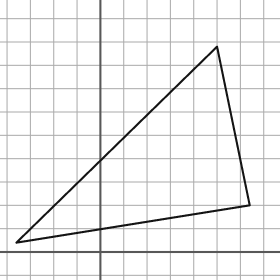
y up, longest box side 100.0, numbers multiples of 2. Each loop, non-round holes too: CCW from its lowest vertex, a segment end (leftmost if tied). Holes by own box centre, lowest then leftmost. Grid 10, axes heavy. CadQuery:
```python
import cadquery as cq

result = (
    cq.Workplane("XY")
    .moveTo(-36.0, 4.0)
    .lineTo(64.0, 20.0)
    .lineTo(50.0, 88.0)
    .close()
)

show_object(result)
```